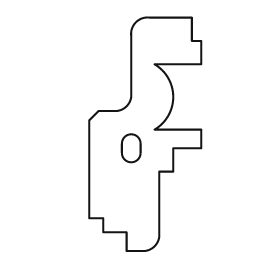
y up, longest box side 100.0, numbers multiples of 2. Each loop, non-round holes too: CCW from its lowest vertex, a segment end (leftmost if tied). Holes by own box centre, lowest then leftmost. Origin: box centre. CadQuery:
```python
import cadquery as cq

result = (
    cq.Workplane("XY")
    .moveTo(-8.0, -50.0)
    .lineTo(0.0, -50.0)
    .threePointArc((4.0, -48.0), (6.0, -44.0))
    .lineTo(6.0, -16.0)
    .lineTo(12.0, -16.0)
    .lineTo(12.0, -6.0)
    .lineTo(24.0, -6.0)
    .lineTo(24.0, 2.0)
    .lineTo(4.0, 2.0)
    .threePointArc((12.0, 16.0), (4.0, 30.0))
    .lineTo(24.0, 30.0)
    .lineTo(24.0, 40.0)
    .lineTo(20.0, 40.0)
    .lineTo(20.0, 50.0)
    .lineTo(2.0, 50.0)
    .threePointArc((-4.0, 48.0), (-6.0, 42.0))
    .lineTo(-6.0, 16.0)
    .threePointArc((-8.0, 12.0), (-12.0, 10.0))
    .lineTo(-20.0, 10.0)
    .lineTo(-24.0, 6.0)
    .lineTo(-24.0, -36.0)
    .lineTo(-18.0, -36.0)
    .lineTo(-18.0, -42.0)
    .lineTo(-8.0, -42.0)
    .close()
    .moveTo(-10.0, -8.0)
    .threePointArc((-6.0, -12.0), (-2.0, -8.0))
    .lineTo(-2.0, -4.0)
    .threePointArc((-6.0, 0.0), (-10.0, -4.0))
    .close()
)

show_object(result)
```